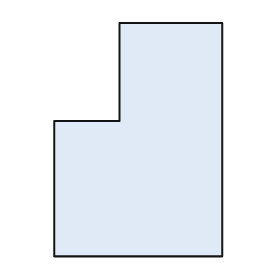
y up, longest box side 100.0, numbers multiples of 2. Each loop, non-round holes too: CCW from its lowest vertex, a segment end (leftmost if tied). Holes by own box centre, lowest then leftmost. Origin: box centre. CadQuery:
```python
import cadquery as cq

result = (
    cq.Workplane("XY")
    .moveTo(-36.0, -50.0)
    .lineTo(36.0, -50.0)
    .lineTo(36.0, 50.0)
    .lineTo(-8.0, 50.0)
    .lineTo(-8.0, 8.0)
    .lineTo(-36.0, 8.0)
    .close()
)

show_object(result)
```